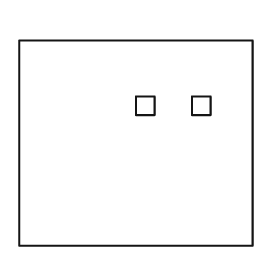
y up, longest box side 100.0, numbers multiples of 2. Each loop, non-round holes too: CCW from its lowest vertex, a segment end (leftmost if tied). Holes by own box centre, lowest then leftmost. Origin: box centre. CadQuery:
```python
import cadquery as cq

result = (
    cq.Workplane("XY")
    .moveTo(-50.0, -44.0)
    .lineTo(50.0, -44.0)
    .lineTo(50.0, 44.0)
    .lineTo(-50.0, 44.0)
    .close()
    .moveTo(0.0, 12.0)
    .lineTo(8.0, 12.0)
    .lineTo(8.0, 20.0)
    .lineTo(0.0, 20.0)
    .close()
    .moveTo(24.0, 12.0)
    .lineTo(32.0, 12.0)
    .lineTo(32.0, 20.0)
    .lineTo(24.0, 20.0)
    .close()
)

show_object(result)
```